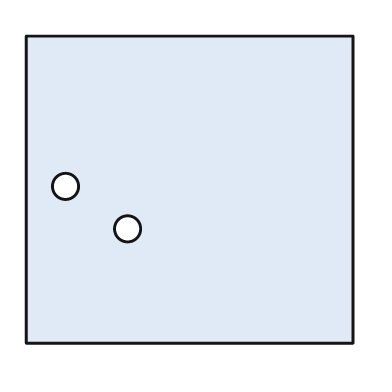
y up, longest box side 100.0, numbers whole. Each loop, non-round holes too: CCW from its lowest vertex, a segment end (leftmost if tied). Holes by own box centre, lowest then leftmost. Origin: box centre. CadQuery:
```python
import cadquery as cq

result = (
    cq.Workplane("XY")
    .moveTo(-50.0, -47.0)
    .lineTo(50.0, -47.0)
    .lineTo(50.0, 47.0)
    .lineTo(-50.0, 47.0)
    .close()
    .moveTo(-19.0, -12.0)
    .circle(4.0)
    .moveTo(-38.0, 1.0)
    .circle(4.0)
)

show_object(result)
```